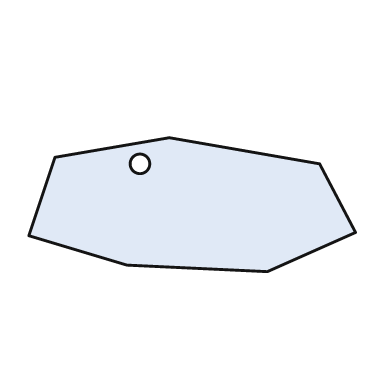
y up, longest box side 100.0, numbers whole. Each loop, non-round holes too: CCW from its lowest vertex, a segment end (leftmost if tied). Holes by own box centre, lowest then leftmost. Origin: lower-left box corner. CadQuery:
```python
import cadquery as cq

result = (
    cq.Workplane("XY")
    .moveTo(73.0, 0.0)
    .lineTo(100.0, 12.0)
    .lineTo(89.0, 33.0)
    .lineTo(43.0, 41.0)
    .lineTo(8.0, 35.0)
    .lineTo(0.0, 11.0)
    .lineTo(30.0, 2.0)
    .close()
    .moveTo(34.0, 33.0)
    .circle(3.0)
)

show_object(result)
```